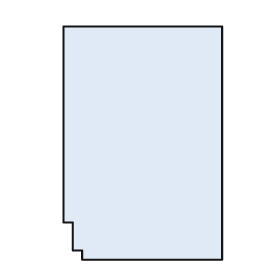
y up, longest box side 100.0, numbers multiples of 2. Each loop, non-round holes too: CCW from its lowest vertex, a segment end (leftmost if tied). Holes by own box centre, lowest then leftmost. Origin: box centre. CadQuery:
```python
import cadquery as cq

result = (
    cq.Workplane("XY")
    .moveTo(-26.0, -50.0)
    .lineTo(34.0, -50.0)
    .lineTo(34.0, 50.0)
    .lineTo(-34.0, 50.0)
    .lineTo(-34.0, -34.0)
    .lineTo(-30.0, -34.0)
    .lineTo(-30.0, -46.0)
    .lineTo(-26.0, -46.0)
    .close()
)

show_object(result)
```